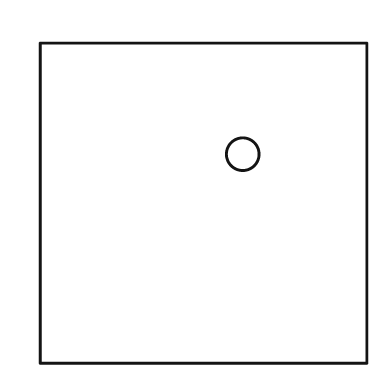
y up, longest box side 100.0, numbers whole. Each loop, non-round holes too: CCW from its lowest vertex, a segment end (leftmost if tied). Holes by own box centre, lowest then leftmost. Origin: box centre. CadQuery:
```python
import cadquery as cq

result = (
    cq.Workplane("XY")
    .moveTo(-50.0, -49.0)
    .lineTo(50.0, -49.0)
    .lineTo(50.0, 49.0)
    .lineTo(-50.0, 49.0)
    .close()
    .moveTo(12.0, 15.0)
    .circle(5.0)
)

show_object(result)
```